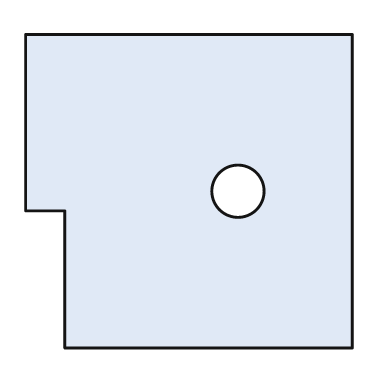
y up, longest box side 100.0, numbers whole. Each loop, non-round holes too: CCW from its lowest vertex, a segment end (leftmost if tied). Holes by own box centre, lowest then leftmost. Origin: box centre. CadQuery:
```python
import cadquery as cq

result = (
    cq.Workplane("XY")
    .moveTo(-38.0, -48.0)
    .lineTo(50.0, -48.0)
    .lineTo(50.0, 48.0)
    .lineTo(-50.0, 48.0)
    .lineTo(-50.0, -6.0)
    .lineTo(-38.0, -6.0)
    .close()
    .moveTo(15.0, 0.0)
    .circle(8.0)
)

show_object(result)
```